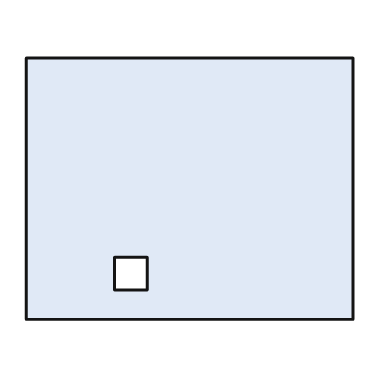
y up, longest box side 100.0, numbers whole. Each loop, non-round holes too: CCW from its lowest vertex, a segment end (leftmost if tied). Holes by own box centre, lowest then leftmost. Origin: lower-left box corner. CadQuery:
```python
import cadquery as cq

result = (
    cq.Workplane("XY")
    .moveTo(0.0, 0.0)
    .lineTo(100.0, 0.0)
    .lineTo(100.0, 80.0)
    .lineTo(0.0, 80.0)
    .close()
    .moveTo(27.0, 9.0)
    .lineTo(37.0, 9.0)
    .lineTo(37.0, 19.0)
    .lineTo(27.0, 19.0)
    .close()
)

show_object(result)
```